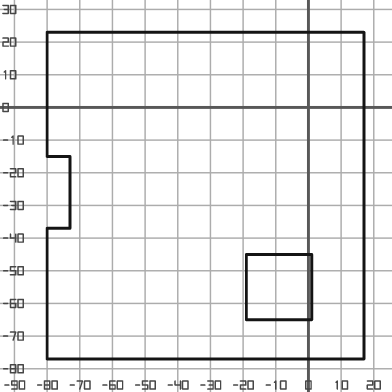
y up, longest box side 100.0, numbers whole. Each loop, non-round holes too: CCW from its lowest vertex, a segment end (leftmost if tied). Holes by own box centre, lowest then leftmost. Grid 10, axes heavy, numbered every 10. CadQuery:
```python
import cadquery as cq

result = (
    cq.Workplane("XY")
    .moveTo(-80.0, -77.0)
    .lineTo(17.0, -77.0)
    .lineTo(17.0, 23.0)
    .lineTo(-80.0, 23.0)
    .lineTo(-80.0, -15.0)
    .lineTo(-73.0, -15.0)
    .lineTo(-73.0, -37.0)
    .lineTo(-80.0, -37.0)
    .close()
    .moveTo(-19.0, -65.0)
    .lineTo(1.0, -65.0)
    .lineTo(1.0, -45.0)
    .lineTo(-19.0, -45.0)
    .close()
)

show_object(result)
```